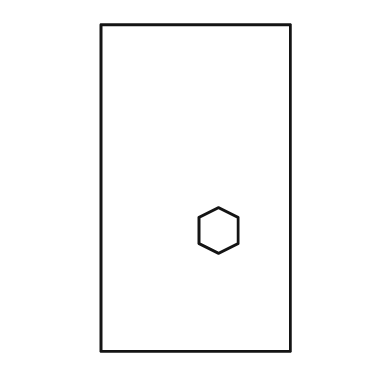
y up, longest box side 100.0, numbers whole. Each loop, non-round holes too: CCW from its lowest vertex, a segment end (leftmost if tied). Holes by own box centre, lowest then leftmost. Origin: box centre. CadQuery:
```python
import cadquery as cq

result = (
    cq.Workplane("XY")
    .moveTo(-29.0, -50.0)
    .lineTo(29.0, -50.0)
    .lineTo(29.0, 50.0)
    .lineTo(-29.0, 50.0)
    .close()
    .moveTo(7.0, -20.0)
    .lineTo(13.0, -17.0)
    .lineTo(13.0, -9.0)
    .lineTo(7.0, -6.0)
    .lineTo(1.0, -9.0)
    .lineTo(1.0, -17.0)
    .close()
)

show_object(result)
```